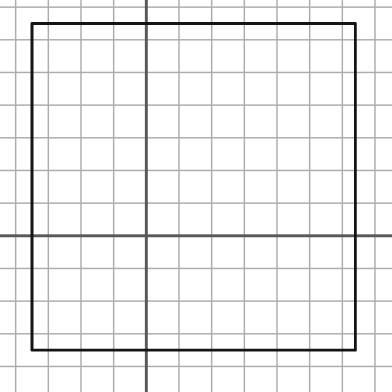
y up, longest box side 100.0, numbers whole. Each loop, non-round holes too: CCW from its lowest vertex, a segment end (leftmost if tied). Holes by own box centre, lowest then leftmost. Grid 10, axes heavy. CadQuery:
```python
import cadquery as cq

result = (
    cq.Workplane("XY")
    .moveTo(-35.0, -35.0)
    .lineTo(64.0, -35.0)
    .lineTo(64.0, 65.0)
    .lineTo(-35.0, 65.0)
    .close()
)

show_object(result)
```